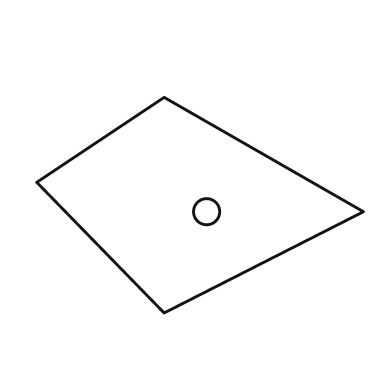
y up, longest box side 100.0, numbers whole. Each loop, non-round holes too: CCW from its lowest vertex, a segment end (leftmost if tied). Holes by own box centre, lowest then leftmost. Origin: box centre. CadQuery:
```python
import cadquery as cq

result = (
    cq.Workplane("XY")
    .moveTo(-11.0, -33.0)
    .lineTo(50.0, -2.0)
    .lineTo(-11.0, 33.0)
    .lineTo(-50.0, 7.0)
    .close()
    .moveTo(2.0, -2.0)
    .circle(4.0)
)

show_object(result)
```